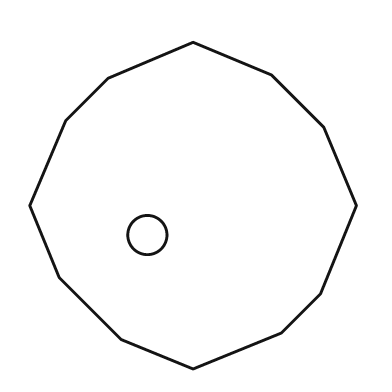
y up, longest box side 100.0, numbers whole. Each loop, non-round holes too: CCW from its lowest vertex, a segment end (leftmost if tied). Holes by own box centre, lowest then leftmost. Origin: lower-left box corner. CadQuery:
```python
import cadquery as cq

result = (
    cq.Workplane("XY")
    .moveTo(50.0, 0.0)
    .lineTo(77.0, 11.0)
    .lineTo(89.0, 23.0)
    .lineTo(100.0, 50.0)
    .lineTo(90.0, 74.0)
    .lineTo(74.0, 90.0)
    .lineTo(50.0, 100.0)
    .lineTo(24.0, 89.0)
    .lineTo(11.0, 76.0)
    .lineTo(0.0, 50.0)
    .lineTo(9.0, 28.0)
    .lineTo(28.0, 9.0)
    .close()
    .moveTo(36.0, 41.0)
    .circle(6.0)
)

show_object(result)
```